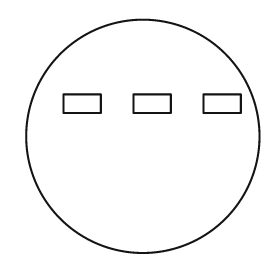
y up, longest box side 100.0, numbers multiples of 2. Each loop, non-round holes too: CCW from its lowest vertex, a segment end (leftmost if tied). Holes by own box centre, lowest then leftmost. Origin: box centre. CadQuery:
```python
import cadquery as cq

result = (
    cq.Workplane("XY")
    .moveTo(0.0, 0.0)
    .circle(50.0)
    .moveTo(-34.0, 10.0)
    .lineTo(-18.0, 10.0)
    .lineTo(-18.0, 18.0)
    .lineTo(-34.0, 18.0)
    .close()
    .moveTo(-4.0, 10.0)
    .lineTo(12.0, 10.0)
    .lineTo(12.0, 18.0)
    .lineTo(-4.0, 18.0)
    .close()
    .moveTo(26.0, 10.0)
    .lineTo(42.0, 10.0)
    .lineTo(42.0, 18.0)
    .lineTo(26.0, 18.0)
    .close()
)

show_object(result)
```